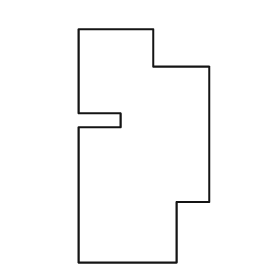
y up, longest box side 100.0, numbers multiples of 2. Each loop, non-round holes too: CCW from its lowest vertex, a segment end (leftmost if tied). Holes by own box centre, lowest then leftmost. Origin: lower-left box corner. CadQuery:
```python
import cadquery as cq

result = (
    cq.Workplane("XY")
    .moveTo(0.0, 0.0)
    .lineTo(42.0, 0.0)
    .lineTo(42.0, 26.0)
    .lineTo(56.0, 26.0)
    .lineTo(56.0, 84.0)
    .lineTo(32.0, 84.0)
    .lineTo(32.0, 100.0)
    .lineTo(0.0, 100.0)
    .lineTo(0.0, 64.0)
    .lineTo(18.0, 64.0)
    .lineTo(18.0, 58.0)
    .lineTo(0.0, 58.0)
    .close()
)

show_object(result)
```